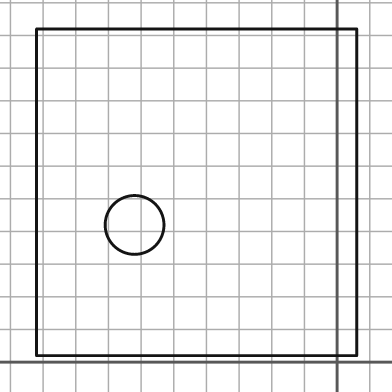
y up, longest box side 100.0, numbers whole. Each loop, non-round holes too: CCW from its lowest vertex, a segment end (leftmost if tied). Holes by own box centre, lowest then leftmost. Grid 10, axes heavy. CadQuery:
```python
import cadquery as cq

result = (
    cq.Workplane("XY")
    .moveTo(-92.0, 2.0)
    .lineTo(6.0, 2.0)
    .lineTo(6.0, 102.0)
    .lineTo(-92.0, 102.0)
    .close()
    .moveTo(-62.0, 42.0)
    .circle(9.0)
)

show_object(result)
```